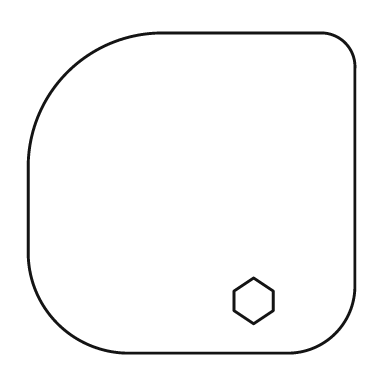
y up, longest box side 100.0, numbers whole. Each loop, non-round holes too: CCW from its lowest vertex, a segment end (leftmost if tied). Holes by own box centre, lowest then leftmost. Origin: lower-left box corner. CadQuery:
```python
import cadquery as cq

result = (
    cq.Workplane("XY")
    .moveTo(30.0, 0.0)
    .lineTo(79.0, 0.0)
    .threePointArc((94.0, 6.0), (100.0, 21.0))
    .lineTo(100.0, 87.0)
    .threePointArc((97.0, 95.0), (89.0, 98.0))
    .lineTo(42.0, 98.0)
    .threePointArc((12.0, 86.0), (0.0, 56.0))
    .lineTo(0.0, 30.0)
    .threePointArc((9.0, 9.0), (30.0, 0.0))
    .close()
    .moveTo(69.0, 9.0)
    .lineTo(75.0, 13.0)
    .lineTo(75.0, 19.0)
    .lineTo(69.0, 23.0)
    .lineTo(63.0, 19.0)
    .lineTo(63.0, 13.0)
    .close()
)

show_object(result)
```